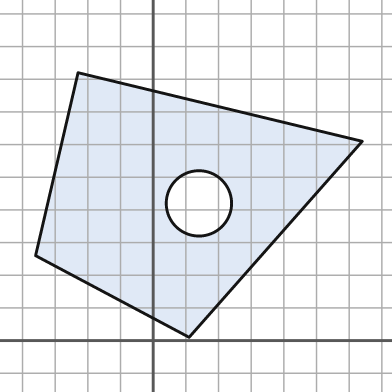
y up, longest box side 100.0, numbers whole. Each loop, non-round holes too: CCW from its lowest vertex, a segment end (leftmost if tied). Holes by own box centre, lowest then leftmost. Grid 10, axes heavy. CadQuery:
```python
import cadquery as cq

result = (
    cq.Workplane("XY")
    .moveTo(11.0, 1.0)
    .lineTo(64.0, 61.0)
    .lineTo(-23.0, 82.0)
    .lineTo(-36.0, 26.0)
    .close()
    .moveTo(14.0, 42.0)
    .circle(10.0)
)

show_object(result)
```